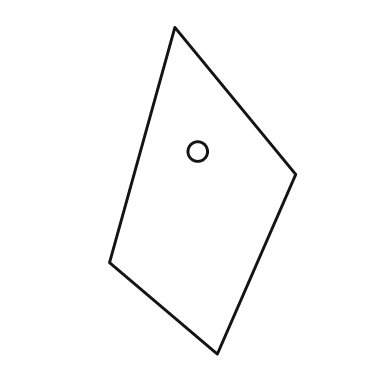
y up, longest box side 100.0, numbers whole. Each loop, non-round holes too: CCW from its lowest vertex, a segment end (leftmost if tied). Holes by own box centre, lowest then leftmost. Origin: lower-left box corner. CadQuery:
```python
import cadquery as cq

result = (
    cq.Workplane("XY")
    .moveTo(33.0, 0.0)
    .lineTo(57.0, 55.0)
    .lineTo(20.0, 100.0)
    .lineTo(0.0, 28.0)
    .close()
    .moveTo(27.0, 62.0)
    .circle(3.0)
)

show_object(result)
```